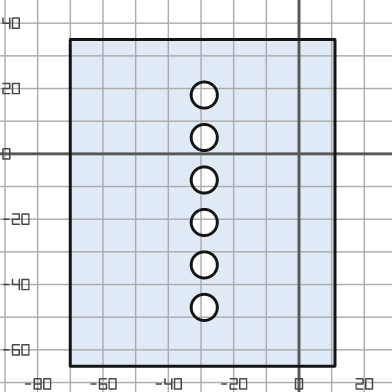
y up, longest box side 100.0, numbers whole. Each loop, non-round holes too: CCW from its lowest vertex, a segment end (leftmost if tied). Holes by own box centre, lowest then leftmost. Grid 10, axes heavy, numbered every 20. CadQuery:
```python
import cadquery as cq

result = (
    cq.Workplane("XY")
    .moveTo(-70.0, -65.0)
    .lineTo(11.0, -65.0)
    .lineTo(11.0, 35.0)
    .lineTo(-70.0, 35.0)
    .close()
    .moveTo(-29.0, -47.0)
    .circle(4.0)
    .moveTo(-29.0, -34.0)
    .circle(4.0)
    .moveTo(-29.0, -21.0)
    .circle(4.0)
    .moveTo(-29.0, -8.0)
    .circle(4.0)
    .moveTo(-29.0, 5.0)
    .circle(4.0)
    .moveTo(-29.0, 18.0)
    .circle(4.0)
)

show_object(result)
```